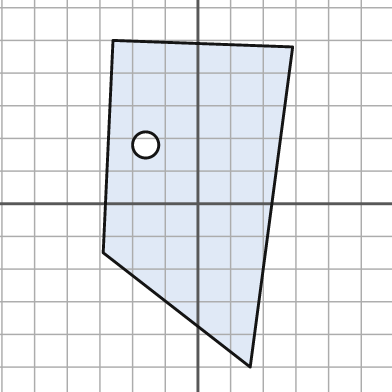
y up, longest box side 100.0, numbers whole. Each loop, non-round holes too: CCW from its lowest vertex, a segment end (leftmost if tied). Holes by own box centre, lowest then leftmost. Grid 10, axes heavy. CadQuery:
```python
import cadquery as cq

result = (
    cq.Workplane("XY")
    .moveTo(16.0, -50.0)
    .lineTo(29.0, 48.0)
    .lineTo(-26.0, 50.0)
    .lineTo(-29.0, -15.0)
    .close()
    .moveTo(-16.0, 18.0)
    .circle(4.0)
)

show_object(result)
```